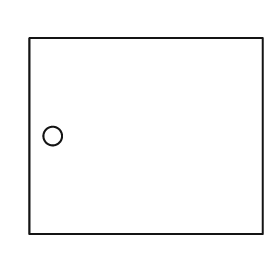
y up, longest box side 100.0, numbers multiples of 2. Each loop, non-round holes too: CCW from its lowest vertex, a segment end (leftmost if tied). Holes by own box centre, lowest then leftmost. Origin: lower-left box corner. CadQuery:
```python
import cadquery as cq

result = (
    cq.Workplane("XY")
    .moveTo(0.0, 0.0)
    .lineTo(100.0, 0.0)
    .lineTo(100.0, 84.0)
    .lineTo(0.0, 84.0)
    .close()
    .moveTo(10.0, 42.0)
    .circle(4.0)
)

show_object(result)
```